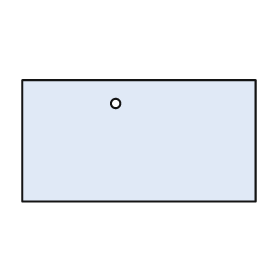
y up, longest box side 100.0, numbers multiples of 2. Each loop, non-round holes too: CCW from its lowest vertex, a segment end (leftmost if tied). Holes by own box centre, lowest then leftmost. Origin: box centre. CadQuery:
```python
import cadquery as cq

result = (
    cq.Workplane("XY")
    .moveTo(-50.0, -26.0)
    .lineTo(50.0, -26.0)
    .lineTo(50.0, 26.0)
    .lineTo(-50.0, 26.0)
    .close()
    .moveTo(-10.0, 16.0)
    .circle(2.0)
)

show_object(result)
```